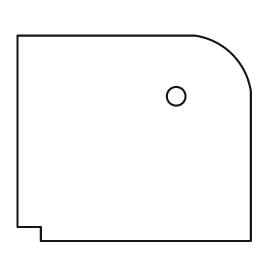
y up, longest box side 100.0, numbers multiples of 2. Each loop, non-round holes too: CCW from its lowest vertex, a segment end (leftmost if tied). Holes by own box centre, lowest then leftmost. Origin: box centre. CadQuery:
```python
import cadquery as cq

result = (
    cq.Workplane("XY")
    .moveTo(-40.0, -44.0)
    .lineTo(50.0, -44.0)
    .lineTo(50.0, 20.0)
    .threePointArc((42.0, 36.0), (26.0, 44.0))
    .lineTo(-50.0, 44.0)
    .lineTo(-50.0, -38.0)
    .lineTo(-40.0, -38.0)
    .close()
    .moveTo(18.0, 18.0)
    .circle(4.0)
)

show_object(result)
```